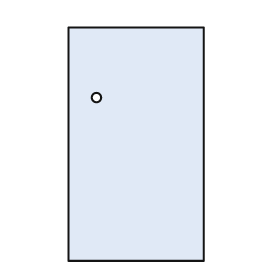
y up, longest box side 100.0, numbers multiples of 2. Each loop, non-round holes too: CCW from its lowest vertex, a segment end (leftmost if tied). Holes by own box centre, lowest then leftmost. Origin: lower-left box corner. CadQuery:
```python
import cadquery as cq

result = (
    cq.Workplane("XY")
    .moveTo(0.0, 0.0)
    .lineTo(58.0, 0.0)
    .lineTo(58.0, 100.0)
    .lineTo(0.0, 100.0)
    .close()
    .moveTo(12.0, 70.0)
    .circle(2.0)
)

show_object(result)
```